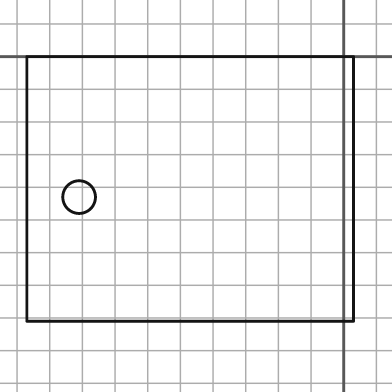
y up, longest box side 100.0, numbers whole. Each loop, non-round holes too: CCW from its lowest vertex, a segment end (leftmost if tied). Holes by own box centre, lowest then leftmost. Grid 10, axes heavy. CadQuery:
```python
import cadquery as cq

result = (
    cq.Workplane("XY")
    .moveTo(-97.0, -81.0)
    .lineTo(3.0, -81.0)
    .lineTo(3.0, 0.0)
    .lineTo(-97.0, 0.0)
    .close()
    .moveTo(-81.0, -43.0)
    .circle(5.0)
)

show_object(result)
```